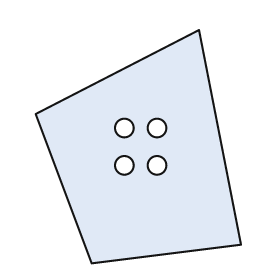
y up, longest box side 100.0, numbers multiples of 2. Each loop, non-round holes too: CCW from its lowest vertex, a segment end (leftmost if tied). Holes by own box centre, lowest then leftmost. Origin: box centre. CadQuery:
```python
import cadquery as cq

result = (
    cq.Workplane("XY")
    .moveTo(-20.0, -50.0)
    .lineTo(44.0, -42.0)
    .lineTo(26.0, 50.0)
    .lineTo(-44.0, 14.0)
    .close()
    .moveTo(-6.0, -8.0)
    .circle(4.0)
    .moveTo(8.0, -8.0)
    .circle(4.0)
    .moveTo(-6.0, 8.0)
    .circle(4.0)
    .moveTo(8.0, 8.0)
    .circle(4.0)
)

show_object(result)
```